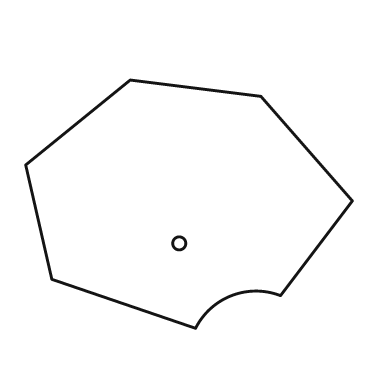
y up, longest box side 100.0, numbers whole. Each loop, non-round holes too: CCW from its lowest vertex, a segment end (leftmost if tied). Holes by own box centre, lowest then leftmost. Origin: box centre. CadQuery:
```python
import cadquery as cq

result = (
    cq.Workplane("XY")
    .moveTo(2.0, -38.0)
    .threePointArc((13.0, -28.0), (28.0, -28.0))
    .lineTo(50.0, 1.0)
    .lineTo(22.0, 33.0)
    .lineTo(-18.0, 38.0)
    .lineTo(-50.0, 12.0)
    .lineTo(-42.0, -23.0)
    .close()
    .moveTo(-3.0, -12.0)
    .circle(2.0)
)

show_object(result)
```